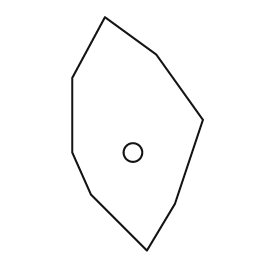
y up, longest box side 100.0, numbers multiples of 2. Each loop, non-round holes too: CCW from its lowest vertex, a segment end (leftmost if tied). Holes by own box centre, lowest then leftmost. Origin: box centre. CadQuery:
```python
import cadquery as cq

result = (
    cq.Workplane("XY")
    .moveTo(4.0, -50.0)
    .lineTo(16.0, -30.0)
    .lineTo(28.0, 6.0)
    .lineTo(8.0, 34.0)
    .lineTo(-14.0, 50.0)
    .lineTo(-28.0, 24.0)
    .lineTo(-28.0, -8.0)
    .lineTo(-20.0, -26.0)
    .close()
    .moveTo(-2.0, -8.0)
    .circle(4.0)
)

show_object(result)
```